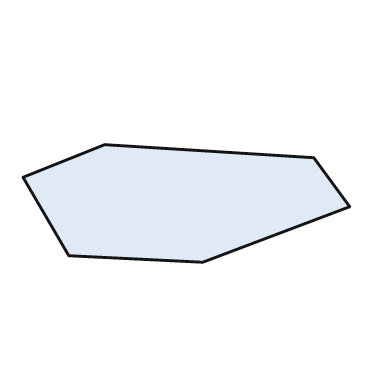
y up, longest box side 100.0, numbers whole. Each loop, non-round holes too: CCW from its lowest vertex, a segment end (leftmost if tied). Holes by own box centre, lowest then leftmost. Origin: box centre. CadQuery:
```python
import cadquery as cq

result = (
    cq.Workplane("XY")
    .moveTo(5.0, -18.0)
    .lineTo(50.0, -1.0)
    .lineTo(39.0, 14.0)
    .lineTo(-25.0, 18.0)
    .lineTo(-50.0, 8.0)
    .lineTo(-36.0, -16.0)
    .close()
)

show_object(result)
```